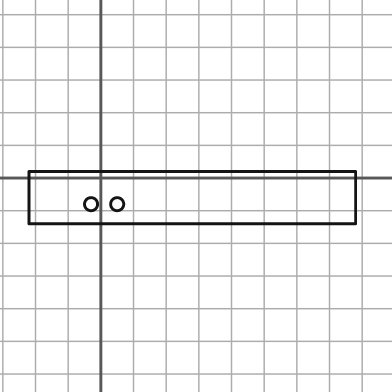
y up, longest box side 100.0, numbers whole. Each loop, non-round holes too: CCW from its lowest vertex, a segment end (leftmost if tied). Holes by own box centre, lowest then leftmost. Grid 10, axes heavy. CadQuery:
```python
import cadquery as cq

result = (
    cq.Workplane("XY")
    .moveTo(-22.0, -14.0)
    .lineTo(78.0, -14.0)
    .lineTo(78.0, 2.0)
    .lineTo(-22.0, 2.0)
    .close()
    .moveTo(-3.0, -8.0)
    .circle(2.0)
    .moveTo(5.0, -8.0)
    .circle(2.0)
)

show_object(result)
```